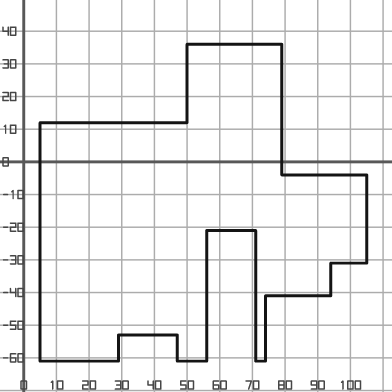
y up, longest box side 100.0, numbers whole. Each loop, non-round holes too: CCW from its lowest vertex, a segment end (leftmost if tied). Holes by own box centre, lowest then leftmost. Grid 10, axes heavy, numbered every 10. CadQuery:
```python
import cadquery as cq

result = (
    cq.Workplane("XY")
    .moveTo(5.0, -61.0)
    .lineTo(29.0, -61.0)
    .lineTo(29.0, -53.0)
    .lineTo(47.0, -53.0)
    .lineTo(47.0, -61.0)
    .lineTo(56.0, -61.0)
    .lineTo(56.0, -21.0)
    .lineTo(71.0, -21.0)
    .lineTo(71.0, -61.0)
    .lineTo(74.0, -61.0)
    .lineTo(74.0, -41.0)
    .lineTo(94.0, -41.0)
    .lineTo(94.0, -31.0)
    .lineTo(105.0, -31.0)
    .lineTo(105.0, -4.0)
    .lineTo(79.0, -4.0)
    .lineTo(79.0, 36.0)
    .lineTo(50.0, 36.0)
    .lineTo(50.0, 12.0)
    .lineTo(5.0, 12.0)
    .close()
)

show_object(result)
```